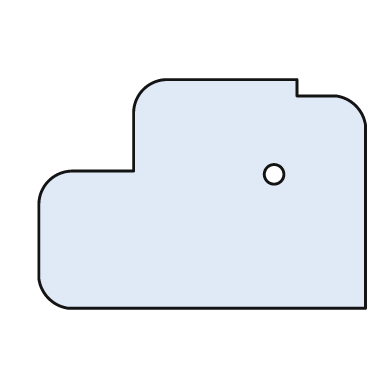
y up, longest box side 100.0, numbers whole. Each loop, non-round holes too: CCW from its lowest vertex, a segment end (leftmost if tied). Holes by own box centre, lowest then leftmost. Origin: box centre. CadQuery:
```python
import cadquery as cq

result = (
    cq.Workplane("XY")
    .moveTo(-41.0, -35.0)
    .lineTo(50.0, -35.0)
    .lineTo(50.0, 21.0)
    .threePointArc((47.0, 27.0), (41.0, 30.0))
    .lineTo(29.0, 30.0)
    .lineTo(29.0, 35.0)
    .lineTo(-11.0, 35.0)
    .threePointArc((-18.0, 32.0), (-21.0, 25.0))
    .lineTo(-21.0, 7.0)
    .lineTo(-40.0, 7.0)
    .threePointArc((-47.0, 4.0), (-50.0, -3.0))
    .lineTo(-50.0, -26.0)
    .threePointArc((-47.0, -32.0), (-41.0, -35.0))
    .close()
    .moveTo(22.0, 6.0)
    .circle(3.0)
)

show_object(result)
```